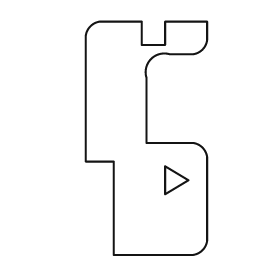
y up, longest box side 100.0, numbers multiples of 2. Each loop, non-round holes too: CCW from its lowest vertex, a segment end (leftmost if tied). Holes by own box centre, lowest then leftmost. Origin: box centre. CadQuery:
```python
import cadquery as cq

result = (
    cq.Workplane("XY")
    .moveTo(-14.0, -50.0)
    .lineTo(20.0, -50.0)
    .threePointArc((24.0, -48.0), (26.0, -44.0))
    .lineTo(26.0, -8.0)
    .threePointArc((24.0, -4.0), (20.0, -2.0))
    .lineTo(0.0, -2.0)
    .lineTo(0.0, 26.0)
    .threePointArc((2.0, 34.0), (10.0, 36.0))
    .lineTo(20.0, 36.0)
    .threePointArc((24.0, 38.0), (26.0, 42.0))
    .lineTo(26.0, 50.0)
    .lineTo(8.0, 50.0)
    .lineTo(8.0, 40.0)
    .lineTo(-2.0, 40.0)
    .lineTo(-2.0, 50.0)
    .lineTo(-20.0, 50.0)
    .threePointArc((-24.0, 48.0), (-26.0, 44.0))
    .lineTo(-26.0, -10.0)
    .lineTo(-14.0, -10.0)
    .close()
    .moveTo(8.0, -24.0)
    .lineTo(18.0, -18.0)
    .lineTo(8.0, -12.0)
    .close()
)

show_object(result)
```